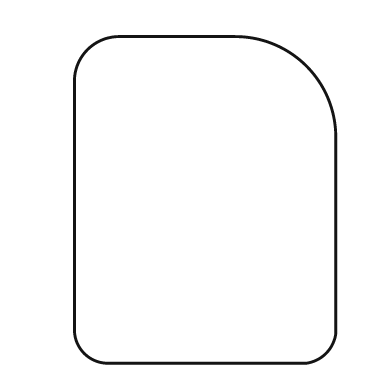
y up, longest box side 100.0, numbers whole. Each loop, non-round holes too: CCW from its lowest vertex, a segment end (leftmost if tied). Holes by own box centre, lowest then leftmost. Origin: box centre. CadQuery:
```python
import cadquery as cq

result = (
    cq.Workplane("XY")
    .moveTo(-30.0, -50.0)
    .lineTo(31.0, -50.0)
    .threePointArc((37.0, -47.0), (40.0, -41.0))
    .lineTo(40.0, 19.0)
    .threePointArc((31.0, 41.0), (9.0, 50.0))
    .lineTo(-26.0, 50.0)
    .threePointArc((-36.0, 46.0), (-40.0, 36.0))
    .lineTo(-40.0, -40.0)
    .threePointArc((-37.0, -47.0), (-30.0, -50.0))
    .close()
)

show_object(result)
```